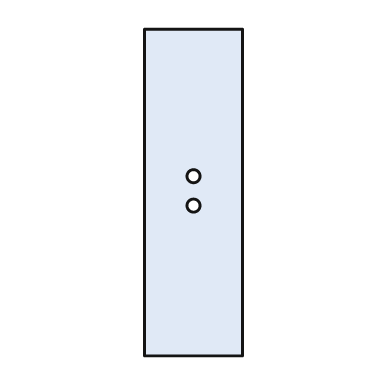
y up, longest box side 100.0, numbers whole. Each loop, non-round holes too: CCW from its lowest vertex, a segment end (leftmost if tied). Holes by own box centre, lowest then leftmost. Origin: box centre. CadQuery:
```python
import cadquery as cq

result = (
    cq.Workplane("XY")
    .moveTo(-15.0, -50.0)
    .lineTo(15.0, -50.0)
    .lineTo(15.0, 50.0)
    .lineTo(-15.0, 50.0)
    .close()
    .moveTo(0.0, -4.0)
    .circle(2.0)
    .moveTo(0.0, 5.0)
    .circle(2.0)
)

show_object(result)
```